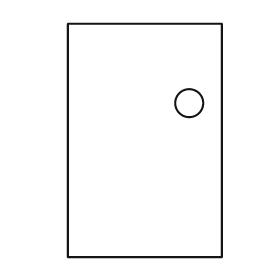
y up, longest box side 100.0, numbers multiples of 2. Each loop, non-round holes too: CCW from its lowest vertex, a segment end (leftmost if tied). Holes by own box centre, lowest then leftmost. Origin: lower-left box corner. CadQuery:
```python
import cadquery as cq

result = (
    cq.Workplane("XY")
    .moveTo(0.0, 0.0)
    .lineTo(66.0, 0.0)
    .lineTo(66.0, 100.0)
    .lineTo(0.0, 100.0)
    .close()
    .moveTo(52.0, 66.0)
    .circle(6.0)
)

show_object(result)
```